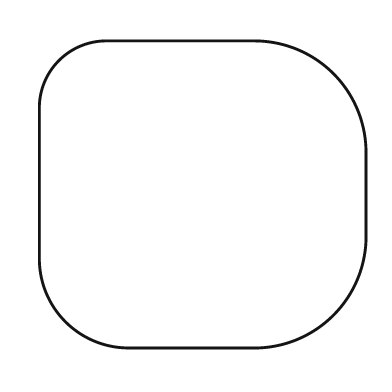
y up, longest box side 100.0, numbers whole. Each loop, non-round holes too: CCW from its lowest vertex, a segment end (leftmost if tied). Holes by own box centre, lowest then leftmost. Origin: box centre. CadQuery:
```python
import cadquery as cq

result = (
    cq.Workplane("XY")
    .moveTo(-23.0, -47.0)
    .lineTo(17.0, -47.0)
    .threePointArc((40.0, -37.0), (50.0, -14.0))
    .lineTo(50.0, 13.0)
    .threePointArc((40.0, 37.0), (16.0, 47.0))
    .lineTo(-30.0, 47.0)
    .threePointArc((-44.0, 41.0), (-50.0, 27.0))
    .lineTo(-50.0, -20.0)
    .threePointArc((-42.0, -39.0), (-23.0, -47.0))
    .close()
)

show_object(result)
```